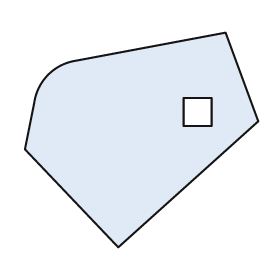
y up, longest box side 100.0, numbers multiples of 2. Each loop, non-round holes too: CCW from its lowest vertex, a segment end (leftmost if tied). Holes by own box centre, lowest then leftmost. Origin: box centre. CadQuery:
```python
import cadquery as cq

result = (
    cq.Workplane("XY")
    .moveTo(-10.0, -46.0)
    .lineTo(50.0, 8.0)
    .lineTo(36.0, 46.0)
    .lineTo(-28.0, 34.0)
    .threePointArc((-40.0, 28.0), (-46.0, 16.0))
    .lineTo(-50.0, -4.0)
    .close()
    .moveTo(18.0, 6.0)
    .lineTo(30.0, 6.0)
    .lineTo(30.0, 18.0)
    .lineTo(18.0, 18.0)
    .close()
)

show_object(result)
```